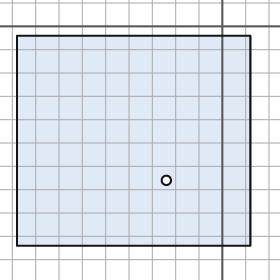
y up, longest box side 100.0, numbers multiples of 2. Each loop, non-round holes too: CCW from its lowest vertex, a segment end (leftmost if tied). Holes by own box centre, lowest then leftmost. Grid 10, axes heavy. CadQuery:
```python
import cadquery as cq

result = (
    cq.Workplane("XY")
    .moveTo(-88.0, -94.0)
    .lineTo(12.0, -94.0)
    .lineTo(12.0, -4.0)
    .lineTo(-88.0, -4.0)
    .close()
    .moveTo(-24.0, -66.0)
    .circle(2.0)
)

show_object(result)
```